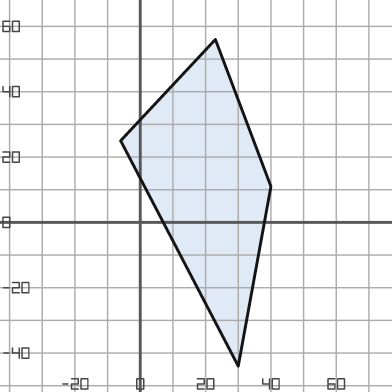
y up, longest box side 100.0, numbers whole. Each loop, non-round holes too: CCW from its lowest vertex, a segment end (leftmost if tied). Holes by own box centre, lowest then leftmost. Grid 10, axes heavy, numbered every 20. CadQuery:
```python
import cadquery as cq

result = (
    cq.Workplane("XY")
    .moveTo(30.0, -44.0)
    .lineTo(40.0, 11.0)
    .lineTo(23.0, 56.0)
    .lineTo(-6.0, 25.0)
    .close()
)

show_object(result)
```